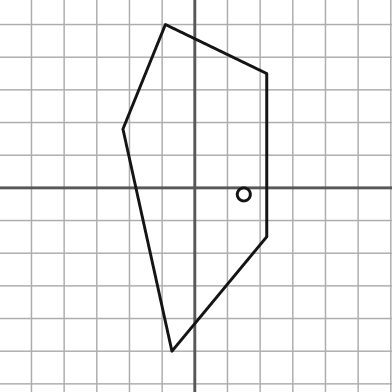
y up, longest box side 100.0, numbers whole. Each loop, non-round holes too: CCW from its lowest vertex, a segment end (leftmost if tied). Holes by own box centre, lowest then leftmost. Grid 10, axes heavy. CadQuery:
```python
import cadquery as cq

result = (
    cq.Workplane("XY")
    .moveTo(-7.0, -50.0)
    .lineTo(22.0, -15.0)
    .lineTo(22.0, 35.0)
    .lineTo(-9.0, 50.0)
    .lineTo(-22.0, 18.0)
    .close()
    .moveTo(15.0, -2.0)
    .circle(2.0)
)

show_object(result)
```